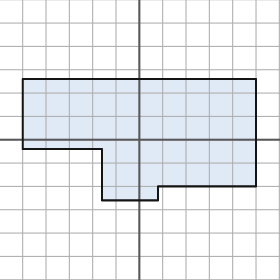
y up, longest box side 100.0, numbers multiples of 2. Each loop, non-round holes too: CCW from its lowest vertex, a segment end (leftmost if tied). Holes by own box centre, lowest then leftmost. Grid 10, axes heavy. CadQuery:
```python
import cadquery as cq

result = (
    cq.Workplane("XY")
    .moveTo(-16.0, -26.0)
    .lineTo(8.0, -26.0)
    .lineTo(8.0, -20.0)
    .lineTo(50.0, -20.0)
    .lineTo(50.0, 26.0)
    .lineTo(-50.0, 26.0)
    .lineTo(-50.0, -4.0)
    .lineTo(-16.0, -4.0)
    .close()
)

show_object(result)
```